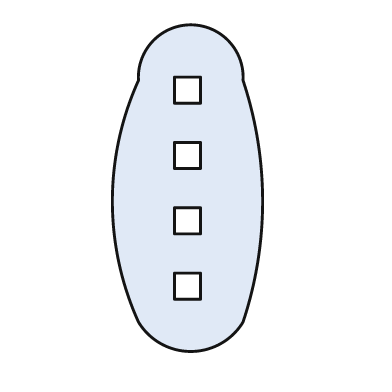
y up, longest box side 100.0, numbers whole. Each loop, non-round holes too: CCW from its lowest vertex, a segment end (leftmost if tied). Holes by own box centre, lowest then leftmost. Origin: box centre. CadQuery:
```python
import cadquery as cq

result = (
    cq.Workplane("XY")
    .moveTo(-15.0, -41.0)
    .threePointArc((1.0, -50.0), (17.0, -41.0))
    .threePointArc((23.0, -4.0), (17.0, 33.0))
    .threePointArc((1.0, 50.0), (-15.0, 33.0))
    .threePointArc((-23.0, -4.0), (-15.0, -41.0))
    .close()
    .moveTo(-4.0, -34.0)
    .lineTo(4.0, -34.0)
    .lineTo(4.0, -26.0)
    .lineTo(-4.0, -26.0)
    .close()
    .moveTo(-4.0, -14.0)
    .lineTo(4.0, -14.0)
    .lineTo(4.0, -6.0)
    .lineTo(-4.0, -6.0)
    .close()
    .moveTo(-4.0, 6.0)
    .lineTo(4.0, 6.0)
    .lineTo(4.0, 14.0)
    .lineTo(-4.0, 14.0)
    .close()
    .moveTo(-4.0, 26.0)
    .lineTo(4.0, 26.0)
    .lineTo(4.0, 34.0)
    .lineTo(-4.0, 34.0)
    .close()
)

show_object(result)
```